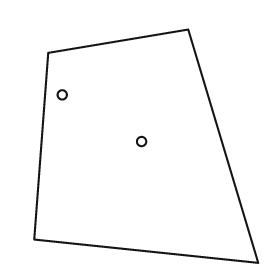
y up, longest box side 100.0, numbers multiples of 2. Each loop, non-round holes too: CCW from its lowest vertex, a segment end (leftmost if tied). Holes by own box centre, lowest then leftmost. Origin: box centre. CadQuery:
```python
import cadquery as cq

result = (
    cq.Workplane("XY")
    .moveTo(48.0, -50.0)
    .lineTo(18.0, 50.0)
    .lineTo(-42.0, 40.0)
    .lineTo(-48.0, -40.0)
    .close()
    .moveTo(-2.0, 2.0)
    .circle(2.0)
    .moveTo(-36.0, 22.0)
    .circle(2.0)
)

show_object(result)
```